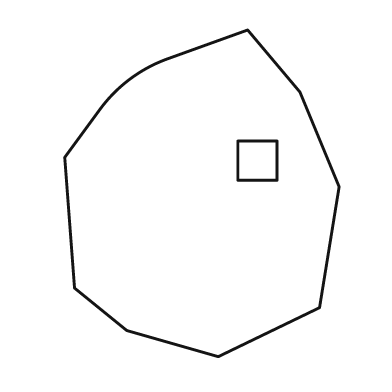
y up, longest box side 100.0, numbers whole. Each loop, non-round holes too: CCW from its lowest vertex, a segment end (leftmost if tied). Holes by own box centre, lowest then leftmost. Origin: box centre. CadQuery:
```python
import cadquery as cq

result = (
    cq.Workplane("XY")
    .moveTo(5.0, -50.0)
    .lineTo(36.0, -35.0)
    .lineTo(42.0, 2.0)
    .lineTo(30.0, 31.0)
    .lineTo(14.0, 50.0)
    .lineTo(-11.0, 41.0)
    .threePointArc((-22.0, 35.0), (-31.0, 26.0))
    .lineTo(-42.0, 11.0)
    .lineTo(-39.0, -29.0)
    .lineTo(-23.0, -42.0)
    .close()
    .moveTo(11.0, 4.0)
    .lineTo(23.0, 4.0)
    .lineTo(23.0, 16.0)
    .lineTo(11.0, 16.0)
    .close()
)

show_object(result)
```